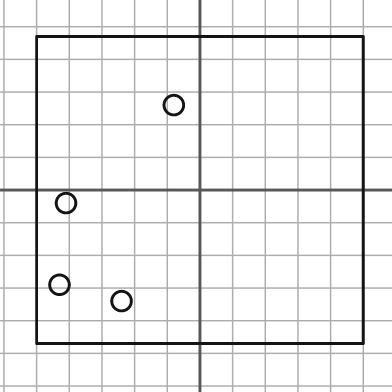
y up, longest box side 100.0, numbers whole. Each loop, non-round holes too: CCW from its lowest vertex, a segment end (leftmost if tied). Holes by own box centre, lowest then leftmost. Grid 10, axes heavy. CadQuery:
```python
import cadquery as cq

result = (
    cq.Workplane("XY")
    .moveTo(-50.0, -47.0)
    .lineTo(50.0, -47.0)
    .lineTo(50.0, 47.0)
    .lineTo(-50.0, 47.0)
    .close()
    .moveTo(-24.0, -34.0)
    .circle(3.0)
    .moveTo(-43.0, -29.0)
    .circle(3.0)
    .moveTo(-41.0, -4.0)
    .circle(3.0)
    .moveTo(-8.0, 26.0)
    .circle(3.0)
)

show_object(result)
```